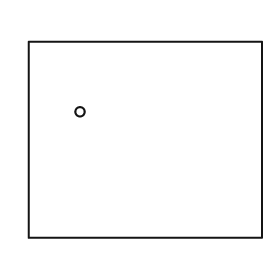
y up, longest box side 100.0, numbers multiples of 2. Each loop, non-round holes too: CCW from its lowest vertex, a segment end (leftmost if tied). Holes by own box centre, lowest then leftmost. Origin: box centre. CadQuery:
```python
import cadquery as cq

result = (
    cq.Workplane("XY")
    .moveTo(-50.0, -42.0)
    .lineTo(50.0, -42.0)
    .lineTo(50.0, 42.0)
    .lineTo(-50.0, 42.0)
    .close()
    .moveTo(-28.0, 12.0)
    .circle(2.0)
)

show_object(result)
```